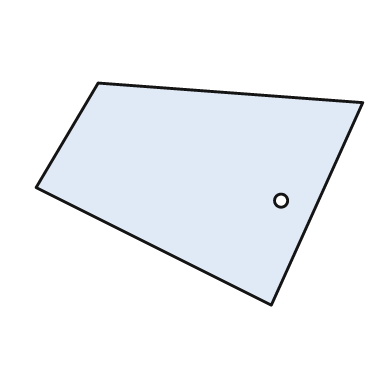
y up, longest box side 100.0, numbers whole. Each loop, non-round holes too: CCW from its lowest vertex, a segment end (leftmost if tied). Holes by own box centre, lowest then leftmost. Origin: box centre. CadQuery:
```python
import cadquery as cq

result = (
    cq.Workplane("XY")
    .moveTo(22.0, -34.0)
    .lineTo(50.0, 28.0)
    .lineTo(-31.0, 34.0)
    .lineTo(-50.0, 2.0)
    .close()
    .moveTo(25.0, -2.0)
    .circle(2.0)
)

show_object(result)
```